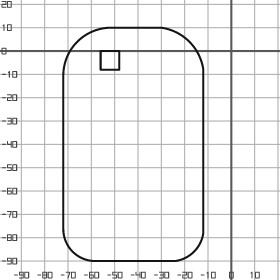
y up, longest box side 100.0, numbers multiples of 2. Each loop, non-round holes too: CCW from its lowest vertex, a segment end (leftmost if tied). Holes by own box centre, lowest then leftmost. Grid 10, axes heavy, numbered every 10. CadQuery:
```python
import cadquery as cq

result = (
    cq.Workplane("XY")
    .moveTo(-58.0, -90.0)
    .lineTo(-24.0, -90.0)
    .threePointArc((-16.0, -86.0), (-12.0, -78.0))
    .lineTo(-12.0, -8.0)
    .threePointArc((-18.0, 4.0), (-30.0, 10.0))
    .lineTo(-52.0, 10.0)
    .threePointArc((-66.0, 4.0), (-72.0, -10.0))
    .lineTo(-72.0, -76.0)
    .threePointArc((-68.0, -86.0), (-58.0, -90.0))
    .close()
    .moveTo(-56.0, -8.0)
    .lineTo(-48.0, -8.0)
    .lineTo(-48.0, 0.0)
    .lineTo(-56.0, 0.0)
    .close()
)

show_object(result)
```